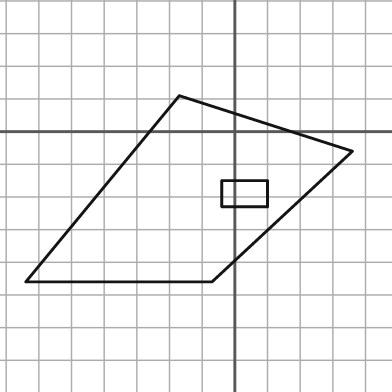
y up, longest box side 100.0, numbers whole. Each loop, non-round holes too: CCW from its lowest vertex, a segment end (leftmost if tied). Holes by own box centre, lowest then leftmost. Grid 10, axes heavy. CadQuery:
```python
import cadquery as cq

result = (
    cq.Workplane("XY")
    .moveTo(-64.0, -46.0)
    .lineTo(-7.0, -46.0)
    .lineTo(36.0, -6.0)
    .lineTo(-17.0, 11.0)
    .close()
    .moveTo(-4.0, -23.0)
    .lineTo(10.0, -23.0)
    .lineTo(10.0, -15.0)
    .lineTo(-4.0, -15.0)
    .close()
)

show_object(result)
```